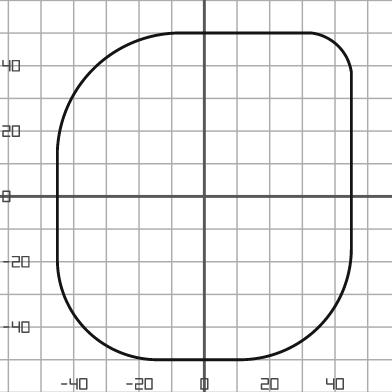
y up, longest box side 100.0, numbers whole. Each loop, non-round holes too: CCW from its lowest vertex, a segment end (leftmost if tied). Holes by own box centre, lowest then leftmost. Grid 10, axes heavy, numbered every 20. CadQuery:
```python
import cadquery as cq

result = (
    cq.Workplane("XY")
    .moveTo(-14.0, -50.0)
    .lineTo(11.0, -50.0)
    .threePointArc((35.0, -40.0), (45.0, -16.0))
    .lineTo(45.0, 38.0)
    .threePointArc((41.0, 46.0), (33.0, 50.0))
    .lineTo(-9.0, 50.0)
    .threePointArc((-34.0, 39.0), (-45.0, 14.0))
    .lineTo(-45.0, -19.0)
    .threePointArc((-36.0, -41.0), (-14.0, -50.0))
    .close()
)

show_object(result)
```